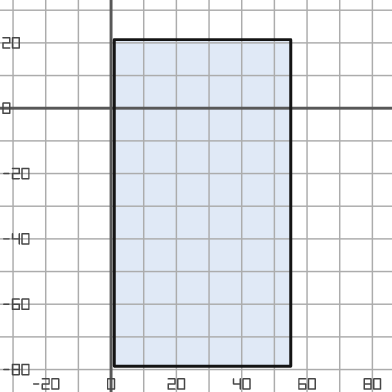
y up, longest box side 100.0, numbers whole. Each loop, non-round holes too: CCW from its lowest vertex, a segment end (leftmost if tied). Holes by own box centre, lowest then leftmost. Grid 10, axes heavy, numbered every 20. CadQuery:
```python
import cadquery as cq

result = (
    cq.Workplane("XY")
    .moveTo(1.0, -79.0)
    .lineTo(55.0, -79.0)
    .lineTo(55.0, 21.0)
    .lineTo(1.0, 21.0)
    .close()
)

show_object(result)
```